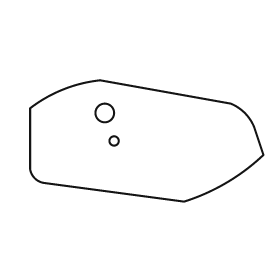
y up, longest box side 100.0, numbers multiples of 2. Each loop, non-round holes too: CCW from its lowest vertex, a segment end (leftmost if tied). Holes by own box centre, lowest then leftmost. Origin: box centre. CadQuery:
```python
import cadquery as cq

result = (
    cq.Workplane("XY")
    .moveTo(16.0, -26.0)
    .threePointArc((34.0, -18.0), (50.0, -6.0))
    .lineTo(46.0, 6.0)
    .threePointArc((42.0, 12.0), (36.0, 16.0))
    .lineTo(-20.0, 26.0)
    .threePointArc((-36.0, 22.0), (-50.0, 14.0))
    .lineTo(-50.0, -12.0)
    .threePointArc((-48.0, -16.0), (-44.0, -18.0))
    .close()
    .moveTo(-14.0, 0.0)
    .circle(2.0)
    .moveTo(-18.0, 12.0)
    .circle(4.0)
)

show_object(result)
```